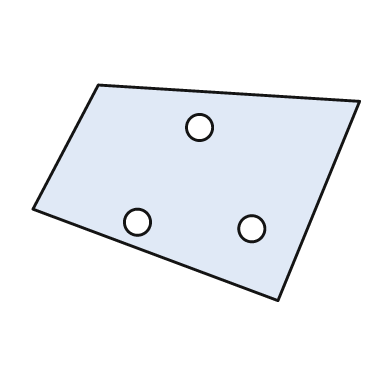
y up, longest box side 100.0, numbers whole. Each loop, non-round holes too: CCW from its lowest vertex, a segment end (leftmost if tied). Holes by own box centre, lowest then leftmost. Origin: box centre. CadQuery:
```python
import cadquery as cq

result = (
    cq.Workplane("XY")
    .moveTo(25.0, -33.0)
    .lineTo(50.0, 28.0)
    .lineTo(-30.0, 33.0)
    .lineTo(-50.0, -5.0)
    .close()
    .moveTo(17.0, -11.0)
    .circle(4.0)
    .moveTo(-18.0, -9.0)
    .circle(4.0)
    .moveTo(1.0, 20.0)
    .circle(4.0)
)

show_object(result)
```